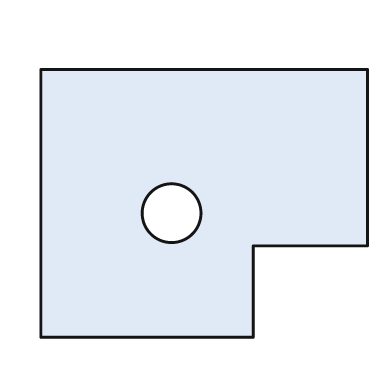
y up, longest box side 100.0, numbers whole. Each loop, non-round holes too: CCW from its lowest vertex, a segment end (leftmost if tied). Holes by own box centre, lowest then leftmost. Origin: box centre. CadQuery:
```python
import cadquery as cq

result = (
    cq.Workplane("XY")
    .moveTo(-50.0, -41.0)
    .lineTo(15.0, -41.0)
    .lineTo(15.0, -13.0)
    .lineTo(50.0, -13.0)
    .lineTo(50.0, 41.0)
    .lineTo(-50.0, 41.0)
    .close()
    .moveTo(-10.0, -3.0)
    .circle(9.0)
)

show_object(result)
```